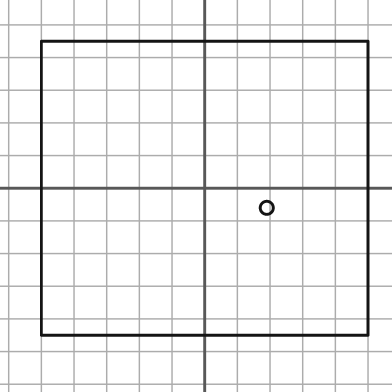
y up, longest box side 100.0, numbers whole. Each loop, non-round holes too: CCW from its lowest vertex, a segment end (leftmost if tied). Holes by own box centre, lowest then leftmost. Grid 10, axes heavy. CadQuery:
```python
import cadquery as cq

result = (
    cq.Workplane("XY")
    .moveTo(-50.0, -45.0)
    .lineTo(50.0, -45.0)
    .lineTo(50.0, 45.0)
    .lineTo(-50.0, 45.0)
    .close()
    .moveTo(19.0, -6.0)
    .circle(2.0)
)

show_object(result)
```